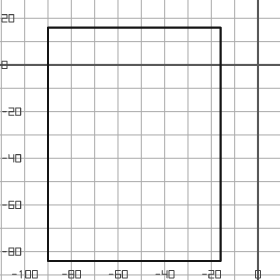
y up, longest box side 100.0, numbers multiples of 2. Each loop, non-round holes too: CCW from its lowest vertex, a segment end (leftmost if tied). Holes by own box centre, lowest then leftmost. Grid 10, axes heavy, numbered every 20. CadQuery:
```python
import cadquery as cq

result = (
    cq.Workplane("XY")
    .moveTo(-90.0, -84.0)
    .lineTo(-16.0, -84.0)
    .lineTo(-16.0, 16.0)
    .lineTo(-90.0, 16.0)
    .close()
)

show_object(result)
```